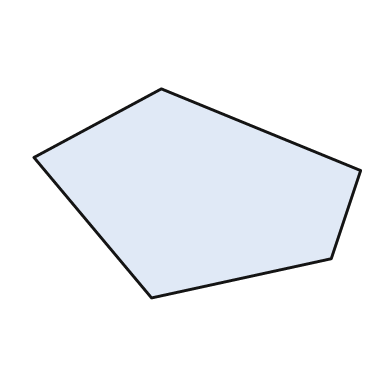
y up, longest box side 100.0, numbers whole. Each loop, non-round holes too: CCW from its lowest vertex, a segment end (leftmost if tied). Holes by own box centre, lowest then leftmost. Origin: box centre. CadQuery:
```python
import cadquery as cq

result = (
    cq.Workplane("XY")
    .moveTo(-14.0, -32.0)
    .lineTo(41.0, -20.0)
    .lineTo(50.0, 7.0)
    .lineTo(-11.0, 32.0)
    .lineTo(-50.0, 11.0)
    .close()
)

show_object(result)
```